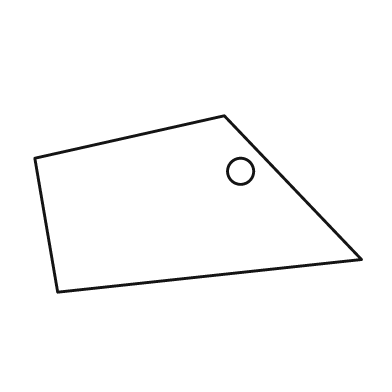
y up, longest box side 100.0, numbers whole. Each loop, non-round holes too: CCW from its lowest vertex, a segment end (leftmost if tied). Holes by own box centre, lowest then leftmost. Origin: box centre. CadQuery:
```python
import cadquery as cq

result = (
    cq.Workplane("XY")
    .moveTo(-43.0, -27.0)
    .lineTo(50.0, -17.0)
    .lineTo(8.0, 27.0)
    .lineTo(-50.0, 14.0)
    .close()
    .moveTo(13.0, 10.0)
    .circle(4.0)
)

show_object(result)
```